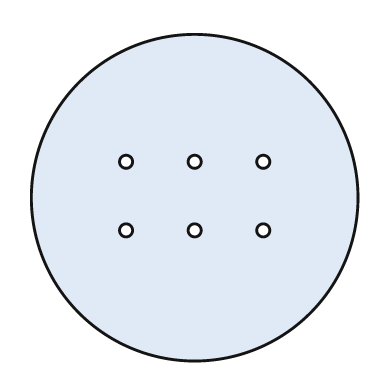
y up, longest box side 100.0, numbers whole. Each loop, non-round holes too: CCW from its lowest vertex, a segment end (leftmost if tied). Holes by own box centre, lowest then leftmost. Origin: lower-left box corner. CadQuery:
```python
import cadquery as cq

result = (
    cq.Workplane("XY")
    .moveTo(50.0, 50.0)
    .circle(50.0)
    .moveTo(29.0, 40.0)
    .circle(2.0)
    .moveTo(50.0, 40.0)
    .circle(2.0)
    .moveTo(71.0, 40.0)
    .circle(2.0)
    .moveTo(29.0, 61.0)
    .circle(2.0)
    .moveTo(50.0, 61.0)
    .circle(2.0)
    .moveTo(71.0, 61.0)
    .circle(2.0)
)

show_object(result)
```